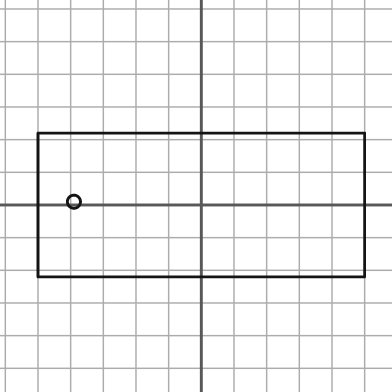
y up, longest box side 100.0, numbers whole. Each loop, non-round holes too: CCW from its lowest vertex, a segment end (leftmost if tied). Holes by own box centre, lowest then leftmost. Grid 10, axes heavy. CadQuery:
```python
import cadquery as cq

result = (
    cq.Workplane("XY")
    .moveTo(-50.0, -22.0)
    .lineTo(50.0, -22.0)
    .lineTo(50.0, 22.0)
    .lineTo(-50.0, 22.0)
    .close()
    .moveTo(-39.0, 1.0)
    .circle(2.0)
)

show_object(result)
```